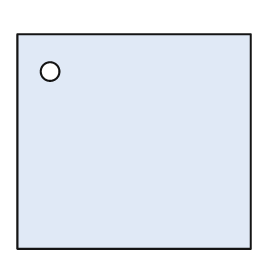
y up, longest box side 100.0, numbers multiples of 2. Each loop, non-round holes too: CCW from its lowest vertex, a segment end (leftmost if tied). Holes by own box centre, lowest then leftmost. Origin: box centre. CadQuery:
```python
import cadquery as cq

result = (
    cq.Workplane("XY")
    .moveTo(-50.0, -46.0)
    .lineTo(50.0, -46.0)
    .lineTo(50.0, 46.0)
    .lineTo(-50.0, 46.0)
    .close()
    .moveTo(-36.0, 30.0)
    .circle(4.0)
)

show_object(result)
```